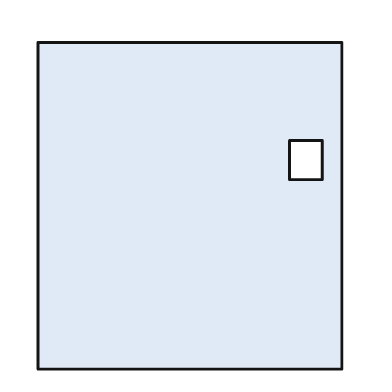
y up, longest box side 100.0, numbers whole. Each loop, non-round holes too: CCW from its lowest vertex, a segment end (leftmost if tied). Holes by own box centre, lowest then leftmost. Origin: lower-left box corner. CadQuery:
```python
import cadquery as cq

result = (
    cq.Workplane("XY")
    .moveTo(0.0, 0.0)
    .lineTo(93.0, 0.0)
    .lineTo(93.0, 100.0)
    .lineTo(0.0, 100.0)
    .close()
    .moveTo(77.0, 58.0)
    .lineTo(87.0, 58.0)
    .lineTo(87.0, 70.0)
    .lineTo(77.0, 70.0)
    .close()
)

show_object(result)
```